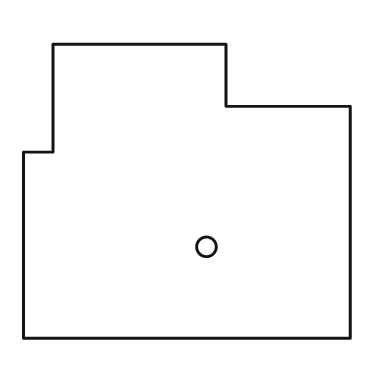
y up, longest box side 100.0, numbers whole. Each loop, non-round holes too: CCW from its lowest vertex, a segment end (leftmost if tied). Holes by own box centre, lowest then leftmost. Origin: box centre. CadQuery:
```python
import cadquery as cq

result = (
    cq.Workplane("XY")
    .moveTo(-50.0, -45.0)
    .lineTo(50.0, -45.0)
    .lineTo(50.0, 26.0)
    .lineTo(12.0, 26.0)
    .lineTo(12.0, 45.0)
    .lineTo(-41.0, 45.0)
    .lineTo(-41.0, 12.0)
    .lineTo(-50.0, 12.0)
    .close()
    .moveTo(6.0, -17.0)
    .circle(3.0)
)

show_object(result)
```